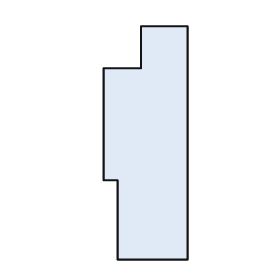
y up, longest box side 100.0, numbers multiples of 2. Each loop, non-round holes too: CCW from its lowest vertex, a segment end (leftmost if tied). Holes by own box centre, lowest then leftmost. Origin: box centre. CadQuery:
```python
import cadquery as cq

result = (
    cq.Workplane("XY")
    .moveTo(-12.0, -50.0)
    .lineTo(18.0, -50.0)
    .lineTo(18.0, 50.0)
    .lineTo(-2.0, 50.0)
    .lineTo(-2.0, 32.0)
    .lineTo(-18.0, 32.0)
    .lineTo(-18.0, -16.0)
    .lineTo(-12.0, -16.0)
    .close()
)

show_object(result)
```